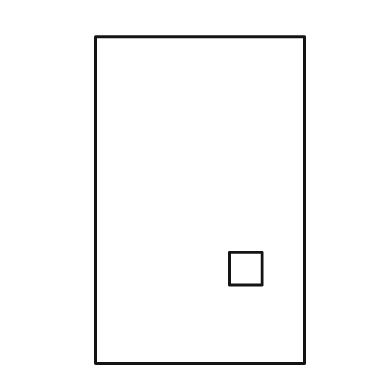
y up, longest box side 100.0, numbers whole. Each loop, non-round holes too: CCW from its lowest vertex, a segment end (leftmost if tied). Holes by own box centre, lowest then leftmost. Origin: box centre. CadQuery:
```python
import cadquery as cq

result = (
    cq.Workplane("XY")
    .moveTo(-32.0, -50.0)
    .lineTo(32.0, -50.0)
    .lineTo(32.0, 50.0)
    .lineTo(-32.0, 50.0)
    .close()
    .moveTo(9.0, -26.0)
    .lineTo(19.0, -26.0)
    .lineTo(19.0, -16.0)
    .lineTo(9.0, -16.0)
    .close()
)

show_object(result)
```